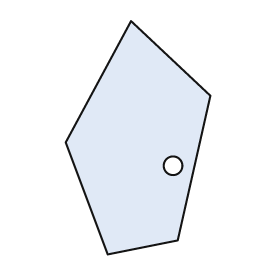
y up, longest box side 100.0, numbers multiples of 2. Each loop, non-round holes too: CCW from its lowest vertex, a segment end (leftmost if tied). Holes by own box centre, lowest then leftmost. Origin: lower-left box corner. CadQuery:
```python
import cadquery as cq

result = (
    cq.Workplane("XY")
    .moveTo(18.0, 0.0)
    .lineTo(48.0, 6.0)
    .lineTo(62.0, 68.0)
    .lineTo(28.0, 100.0)
    .lineTo(0.0, 48.0)
    .close()
    .moveTo(46.0, 38.0)
    .circle(4.0)
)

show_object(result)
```